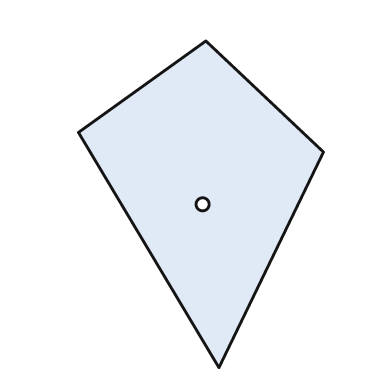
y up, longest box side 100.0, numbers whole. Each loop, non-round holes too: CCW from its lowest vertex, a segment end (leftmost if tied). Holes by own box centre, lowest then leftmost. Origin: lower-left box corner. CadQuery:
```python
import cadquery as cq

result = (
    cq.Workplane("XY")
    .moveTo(43.0, 0.0)
    .lineTo(75.0, 66.0)
    .lineTo(39.0, 100.0)
    .lineTo(0.0, 72.0)
    .close()
    .moveTo(38.0, 50.0)
    .circle(2.0)
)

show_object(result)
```